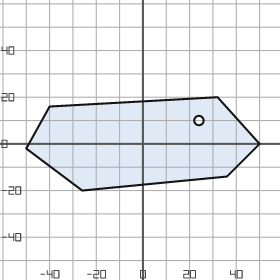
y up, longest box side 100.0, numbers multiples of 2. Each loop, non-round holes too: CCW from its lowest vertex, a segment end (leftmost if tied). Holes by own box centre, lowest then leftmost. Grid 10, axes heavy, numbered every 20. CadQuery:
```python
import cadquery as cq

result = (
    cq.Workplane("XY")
    .moveTo(-26.0, -20.0)
    .lineTo(36.0, -14.0)
    .lineTo(50.0, 0.0)
    .lineTo(32.0, 20.0)
    .lineTo(-40.0, 16.0)
    .lineTo(-50.0, -2.0)
    .close()
    .moveTo(24.0, 10.0)
    .circle(2.0)
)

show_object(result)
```